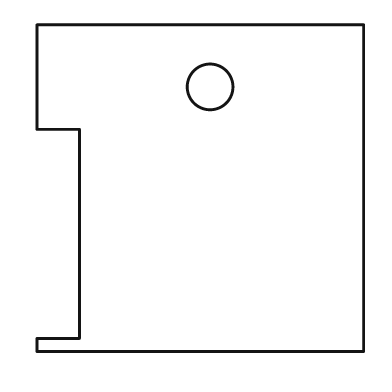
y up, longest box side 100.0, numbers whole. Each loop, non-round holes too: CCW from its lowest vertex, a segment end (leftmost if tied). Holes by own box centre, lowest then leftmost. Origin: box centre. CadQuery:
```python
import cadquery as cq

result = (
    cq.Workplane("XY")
    .moveTo(-50.0, -50.0)
    .lineTo(50.0, -50.0)
    .lineTo(50.0, 50.0)
    .lineTo(-50.0, 50.0)
    .lineTo(-50.0, 18.0)
    .lineTo(-37.0, 18.0)
    .lineTo(-37.0, -46.0)
    .lineTo(-50.0, -46.0)
    .close()
    .moveTo(3.0, 31.0)
    .circle(7.0)
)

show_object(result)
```